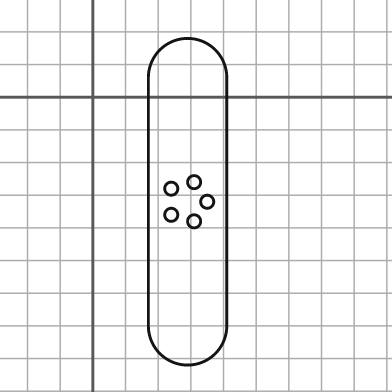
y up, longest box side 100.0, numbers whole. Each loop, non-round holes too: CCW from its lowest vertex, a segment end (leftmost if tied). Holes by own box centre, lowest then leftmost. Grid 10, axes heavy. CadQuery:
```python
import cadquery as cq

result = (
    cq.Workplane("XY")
    .moveTo(17.0, -70.0)
    .threePointArc((29.0, -82.0), (41.0, -70.0))
    .lineTo(41.0, 6.0)
    .threePointArc((29.0, 18.0), (17.0, 6.0))
    .close()
    .moveTo(31.0, -38.0)
    .circle(2.0)
    .moveTo(24.0, -36.0)
    .circle(2.0)
    .moveTo(35.0, -32.0)
    .circle(2.0)
    .moveTo(24.0, -28.0)
    .circle(2.0)
    .moveTo(31.0, -26.0)
    .circle(2.0)
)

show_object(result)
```